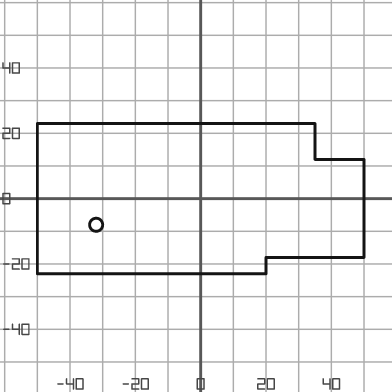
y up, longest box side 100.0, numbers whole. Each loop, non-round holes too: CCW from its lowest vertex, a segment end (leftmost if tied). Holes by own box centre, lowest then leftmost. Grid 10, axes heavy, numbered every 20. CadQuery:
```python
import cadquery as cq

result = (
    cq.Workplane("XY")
    .moveTo(-50.0, -23.0)
    .lineTo(20.0, -23.0)
    .lineTo(20.0, -18.0)
    .lineTo(50.0, -18.0)
    .lineTo(50.0, 12.0)
    .lineTo(35.0, 12.0)
    .lineTo(35.0, 23.0)
    .lineTo(-50.0, 23.0)
    .close()
    .moveTo(-32.0, -8.0)
    .circle(2.0)
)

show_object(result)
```